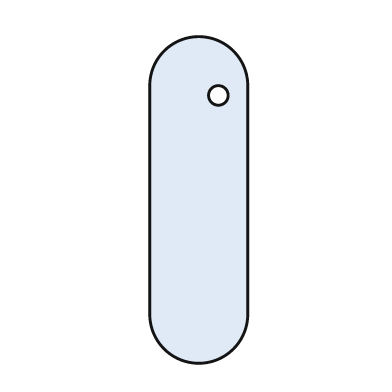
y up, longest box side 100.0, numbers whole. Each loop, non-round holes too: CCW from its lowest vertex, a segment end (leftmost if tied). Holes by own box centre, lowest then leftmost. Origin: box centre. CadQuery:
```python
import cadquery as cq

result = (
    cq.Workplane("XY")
    .moveTo(-15.0, -35.0)
    .threePointArc((0.0, -50.0), (15.0, -35.0))
    .lineTo(15.0, 35.0)
    .threePointArc((0.0, 50.0), (-15.0, 35.0))
    .close()
    .moveTo(6.0, 32.0)
    .circle(3.0)
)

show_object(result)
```